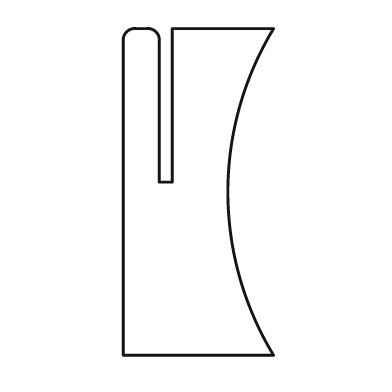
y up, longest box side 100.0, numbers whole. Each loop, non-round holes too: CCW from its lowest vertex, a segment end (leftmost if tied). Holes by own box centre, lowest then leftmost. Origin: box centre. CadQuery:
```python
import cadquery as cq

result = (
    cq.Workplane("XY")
    .moveTo(-23.0, -50.0)
    .lineTo(23.0, -50.0)
    .threePointArc((9.0, 0.0), (23.0, 50.0))
    .lineTo(-8.0, 50.0)
    .lineTo(-8.0, 3.0)
    .lineTo(-12.0, 3.0)
    .lineTo(-12.0, 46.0)
    .threePointArc((-13.0, 49.0), (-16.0, 50.0))
    .lineTo(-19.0, 50.0)
    .threePointArc((-22.0, 49.0), (-23.0, 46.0))
    .close()
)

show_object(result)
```